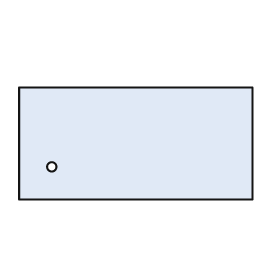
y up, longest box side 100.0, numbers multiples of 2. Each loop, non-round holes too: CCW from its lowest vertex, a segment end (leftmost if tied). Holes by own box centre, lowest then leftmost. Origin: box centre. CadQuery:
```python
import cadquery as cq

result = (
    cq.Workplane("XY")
    .moveTo(-50.0, -24.0)
    .lineTo(50.0, -24.0)
    .lineTo(50.0, 24.0)
    .lineTo(-50.0, 24.0)
    .close()
    .moveTo(-36.0, -10.0)
    .circle(2.0)
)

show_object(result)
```